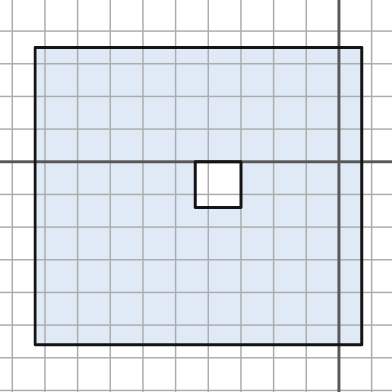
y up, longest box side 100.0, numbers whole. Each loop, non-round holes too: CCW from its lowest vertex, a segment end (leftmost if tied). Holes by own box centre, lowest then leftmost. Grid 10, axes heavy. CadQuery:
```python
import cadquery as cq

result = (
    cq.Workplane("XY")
    .moveTo(-93.0, -56.0)
    .lineTo(7.0, -56.0)
    .lineTo(7.0, 35.0)
    .lineTo(-93.0, 35.0)
    .close()
    .moveTo(-44.0, -14.0)
    .lineTo(-30.0, -14.0)
    .lineTo(-30.0, 0.0)
    .lineTo(-44.0, 0.0)
    .close()
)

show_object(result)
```